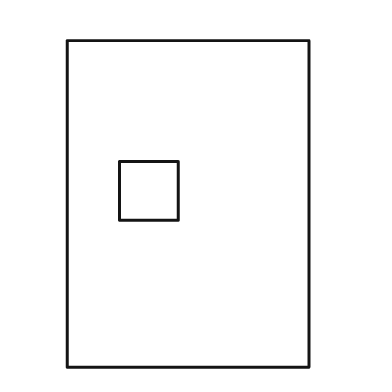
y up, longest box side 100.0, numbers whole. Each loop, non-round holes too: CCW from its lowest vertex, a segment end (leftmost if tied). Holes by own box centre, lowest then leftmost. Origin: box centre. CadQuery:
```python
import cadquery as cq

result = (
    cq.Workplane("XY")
    .moveTo(-37.0, -50.0)
    .lineTo(37.0, -50.0)
    .lineTo(37.0, 50.0)
    .lineTo(-37.0, 50.0)
    .close()
    .moveTo(-21.0, -5.0)
    .lineTo(-3.0, -5.0)
    .lineTo(-3.0, 13.0)
    .lineTo(-21.0, 13.0)
    .close()
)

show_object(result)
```